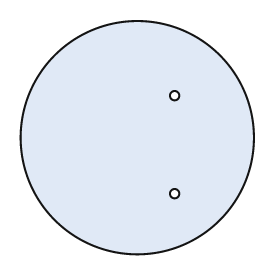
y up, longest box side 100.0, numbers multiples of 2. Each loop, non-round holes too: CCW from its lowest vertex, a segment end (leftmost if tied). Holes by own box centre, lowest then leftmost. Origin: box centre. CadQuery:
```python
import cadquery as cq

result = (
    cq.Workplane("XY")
    .moveTo(0.0, 0.0)
    .circle(50.0)
    .moveTo(16.0, -24.0)
    .circle(2.0)
    .moveTo(16.0, 18.0)
    .circle(2.0)
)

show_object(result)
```